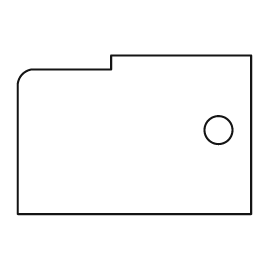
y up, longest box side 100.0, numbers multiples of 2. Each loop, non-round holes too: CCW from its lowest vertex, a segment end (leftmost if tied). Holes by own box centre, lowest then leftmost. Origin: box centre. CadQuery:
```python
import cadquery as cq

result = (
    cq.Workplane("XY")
    .moveTo(-50.0, -34.0)
    .lineTo(50.0, -34.0)
    .lineTo(50.0, 34.0)
    .lineTo(-10.0, 34.0)
    .lineTo(-10.0, 28.0)
    .lineTo(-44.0, 28.0)
    .threePointArc((-48.0, 26.0), (-50.0, 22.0))
    .close()
    .moveTo(36.0, 2.0)
    .circle(6.0)
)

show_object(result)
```